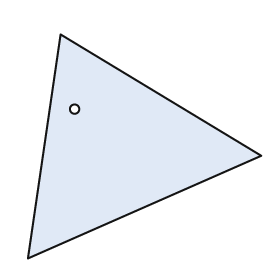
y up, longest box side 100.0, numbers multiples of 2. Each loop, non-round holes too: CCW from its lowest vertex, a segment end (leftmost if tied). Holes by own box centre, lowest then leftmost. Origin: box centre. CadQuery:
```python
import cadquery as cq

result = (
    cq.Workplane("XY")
    .moveTo(-50.0, -48.0)
    .lineTo(50.0, -4.0)
    .lineTo(-36.0, 48.0)
    .close()
    .moveTo(-30.0, 16.0)
    .circle(2.0)
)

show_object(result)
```